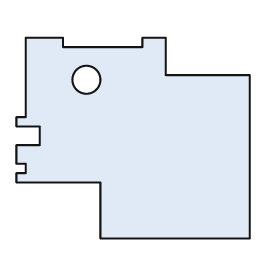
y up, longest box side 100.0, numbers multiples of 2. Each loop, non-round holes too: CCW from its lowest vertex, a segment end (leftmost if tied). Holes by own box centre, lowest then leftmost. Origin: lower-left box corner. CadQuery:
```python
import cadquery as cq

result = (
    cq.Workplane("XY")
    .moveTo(36.0, 0.0)
    .lineTo(100.0, 0.0)
    .lineTo(100.0, 70.0)
    .lineTo(64.0, 70.0)
    .lineTo(64.0, 86.0)
    .lineTo(54.0, 86.0)
    .lineTo(54.0, 82.0)
    .lineTo(20.0, 82.0)
    .lineTo(20.0, 86.0)
    .lineTo(4.0, 86.0)
    .lineTo(4.0, 52.0)
    .lineTo(0.0, 52.0)
    .lineTo(0.0, 48.0)
    .lineTo(10.0, 48.0)
    .lineTo(10.0, 40.0)
    .lineTo(0.0, 40.0)
    .lineTo(0.0, 32.0)
    .lineTo(4.0, 32.0)
    .lineTo(4.0, 28.0)
    .lineTo(0.0, 28.0)
    .lineTo(0.0, 24.0)
    .lineTo(36.0, 24.0)
    .close()
    .moveTo(30.0, 68.0)
    .circle(6.0)
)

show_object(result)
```